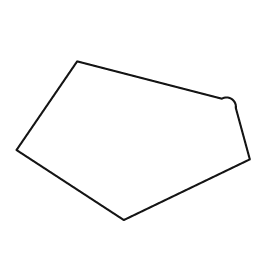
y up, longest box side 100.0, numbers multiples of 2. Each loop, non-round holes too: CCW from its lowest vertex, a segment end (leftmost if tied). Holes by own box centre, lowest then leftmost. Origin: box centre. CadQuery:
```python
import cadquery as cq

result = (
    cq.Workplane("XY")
    .moveTo(-4.0, -34.0)
    .lineTo(50.0, -8.0)
    .lineTo(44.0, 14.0)
    .threePointArc((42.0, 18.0), (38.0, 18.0))
    .lineTo(-24.0, 34.0)
    .lineTo(-50.0, -4.0)
    .close()
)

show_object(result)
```